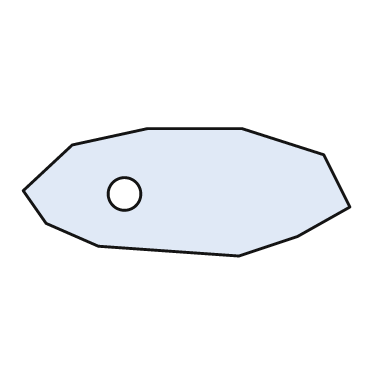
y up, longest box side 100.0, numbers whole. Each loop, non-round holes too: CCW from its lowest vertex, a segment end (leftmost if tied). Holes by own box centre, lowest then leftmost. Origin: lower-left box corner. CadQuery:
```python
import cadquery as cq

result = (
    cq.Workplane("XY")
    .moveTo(66.0, 0.0)
    .lineTo(84.0, 6.0)
    .lineTo(100.0, 15.0)
    .lineTo(92.0, 31.0)
    .lineTo(67.0, 39.0)
    .lineTo(38.0, 39.0)
    .lineTo(15.0, 34.0)
    .lineTo(0.0, 20.0)
    .lineTo(7.0, 10.0)
    .lineTo(23.0, 3.0)
    .close()
    .moveTo(31.0, 19.0)
    .circle(5.0)
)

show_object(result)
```